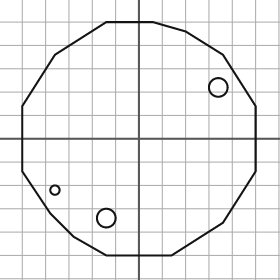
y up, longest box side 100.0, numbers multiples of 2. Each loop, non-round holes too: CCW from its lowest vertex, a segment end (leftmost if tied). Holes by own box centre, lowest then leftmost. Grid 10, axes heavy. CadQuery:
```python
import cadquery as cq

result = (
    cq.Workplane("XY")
    .moveTo(-14.0, -50.0)
    .lineTo(14.0, -50.0)
    .lineTo(36.0, -36.0)
    .lineTo(50.0, -14.0)
    .lineTo(50.0, 14.0)
    .lineTo(36.0, 36.0)
    .lineTo(20.0, 46.0)
    .lineTo(6.0, 50.0)
    .lineTo(-14.0, 50.0)
    .lineTo(-36.0, 36.0)
    .lineTo(-50.0, 14.0)
    .lineTo(-50.0, -14.0)
    .lineTo(-38.0, -32.0)
    .lineTo(-28.0, -42.0)
    .close()
    .moveTo(-14.0, -34.0)
    .circle(4.0)
    .moveTo(-36.0, -22.0)
    .circle(2.0)
    .moveTo(34.0, 22.0)
    .circle(4.0)
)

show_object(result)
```